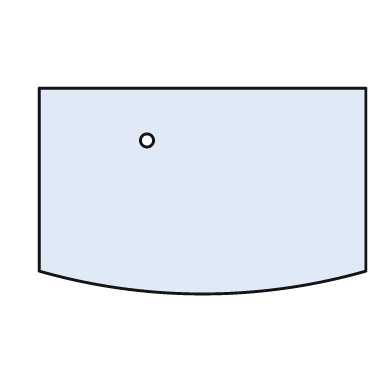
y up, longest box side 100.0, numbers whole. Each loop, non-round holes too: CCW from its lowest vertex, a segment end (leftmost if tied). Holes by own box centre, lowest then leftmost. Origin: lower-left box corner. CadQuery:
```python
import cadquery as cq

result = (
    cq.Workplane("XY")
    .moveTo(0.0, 7.0)
    .threePointArc((50.0, 0.0), (100.0, 7.0))
    .lineTo(100.0, 63.0)
    .lineTo(0.0, 63.0)
    .close()
    .moveTo(33.0, 47.0)
    .circle(2.0)
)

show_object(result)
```